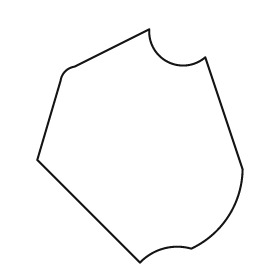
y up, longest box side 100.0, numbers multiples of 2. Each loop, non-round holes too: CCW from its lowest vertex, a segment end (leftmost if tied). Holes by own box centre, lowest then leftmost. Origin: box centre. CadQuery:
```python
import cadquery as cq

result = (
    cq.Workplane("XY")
    .moveTo(0.0, -50.0)
    .threePointArc((10.0, -44.0), (22.0, -44.0))
    .threePointArc((38.0, -30.0), (44.0, -10.0))
    .lineTo(28.0, 38.0)
    .threePointArc((12.0, 36.0), (4.0, 50.0))
    .lineTo(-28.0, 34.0)
    .threePointArc((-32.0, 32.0), (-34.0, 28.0))
    .lineTo(-44.0, -6.0)
    .close()
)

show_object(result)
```